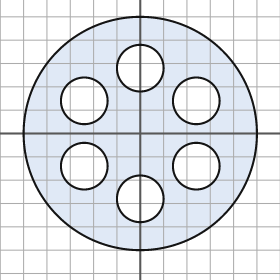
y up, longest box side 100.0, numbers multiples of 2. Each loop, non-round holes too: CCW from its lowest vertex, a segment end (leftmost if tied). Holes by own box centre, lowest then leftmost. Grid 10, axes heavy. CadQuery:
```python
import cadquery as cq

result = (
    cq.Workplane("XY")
    .moveTo(0.0, 0.0)
    .circle(50.0)
    .moveTo(0.0, -28.0)
    .circle(10.0)
    .moveTo(-24.0, -14.0)
    .circle(10.0)
    .moveTo(24.0, -14.0)
    .circle(10.0)
    .moveTo(-24.0, 14.0)
    .circle(10.0)
    .moveTo(24.0, 14.0)
    .circle(10.0)
    .moveTo(0.0, 28.0)
    .circle(10.0)
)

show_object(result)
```